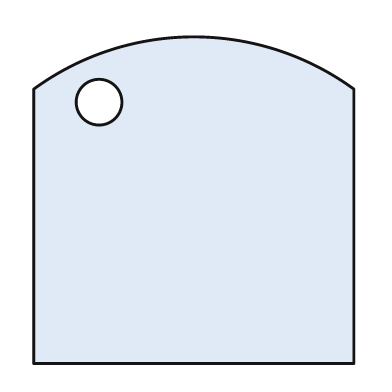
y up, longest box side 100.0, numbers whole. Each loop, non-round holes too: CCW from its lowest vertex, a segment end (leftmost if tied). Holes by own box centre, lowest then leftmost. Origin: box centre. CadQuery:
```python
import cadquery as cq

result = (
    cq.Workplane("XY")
    .moveTo(-49.0, -50.0)
    .lineTo(49.0, -50.0)
    .lineTo(49.0, 34.0)
    .threePointArc((0.0, 50.0), (-49.0, 34.0))
    .close()
    .moveTo(-29.0, 30.0)
    .circle(7.0)
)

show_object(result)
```